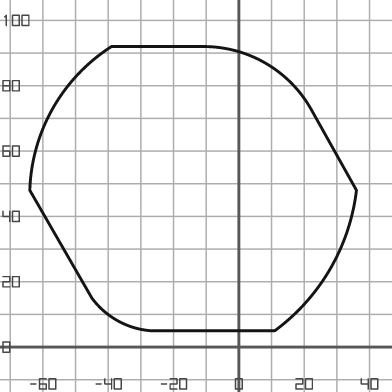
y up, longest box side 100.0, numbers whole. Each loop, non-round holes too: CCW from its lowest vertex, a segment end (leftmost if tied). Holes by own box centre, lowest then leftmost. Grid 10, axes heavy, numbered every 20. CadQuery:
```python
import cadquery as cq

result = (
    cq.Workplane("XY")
    .moveTo(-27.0, 5.0)
    .lineTo(11.0, 5.0)
    .threePointArc((28.0, 24.0), (36.0, 48.0))
    .lineTo(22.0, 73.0)
    .threePointArc((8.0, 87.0), (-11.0, 92.0))
    .lineTo(-39.0, 92.0)
    .threePointArc((-57.0, 73.0), (-64.0, 48.0))
    .lineTo(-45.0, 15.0)
    .threePointArc((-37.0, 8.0), (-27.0, 5.0))
    .close()
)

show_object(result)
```